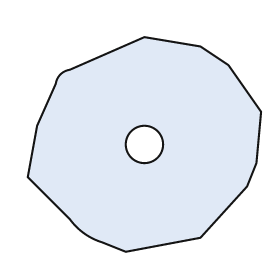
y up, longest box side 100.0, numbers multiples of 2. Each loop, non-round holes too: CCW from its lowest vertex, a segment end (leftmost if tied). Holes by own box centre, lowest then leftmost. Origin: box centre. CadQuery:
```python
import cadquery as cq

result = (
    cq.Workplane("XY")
    .moveTo(-8.0, -46.0)
    .lineTo(24.0, -40.0)
    .lineTo(44.0, -18.0)
    .lineTo(48.0, -8.0)
    .lineTo(50.0, 14.0)
    .lineTo(36.0, 34.0)
    .lineTo(24.0, 42.0)
    .lineTo(0.0, 46.0)
    .lineTo(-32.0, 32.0)
    .threePointArc((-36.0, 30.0), (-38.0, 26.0))
    .lineTo(-46.0, 8.0)
    .lineTo(-50.0, -14.0)
    .lineTo(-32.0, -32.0)
    .threePointArc((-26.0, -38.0), (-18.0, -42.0))
    .close()
    .moveTo(0.0, 0.0)
    .circle(8.0)
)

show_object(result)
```